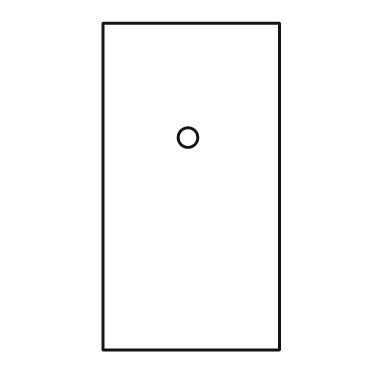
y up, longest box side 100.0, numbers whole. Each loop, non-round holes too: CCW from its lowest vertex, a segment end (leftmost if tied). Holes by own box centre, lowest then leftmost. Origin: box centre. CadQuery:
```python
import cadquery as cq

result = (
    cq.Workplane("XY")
    .moveTo(-27.0, -50.0)
    .lineTo(27.0, -50.0)
    .lineTo(27.0, 50.0)
    .lineTo(-27.0, 50.0)
    .close()
    .moveTo(-1.0, 15.0)
    .circle(3.0)
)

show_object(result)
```